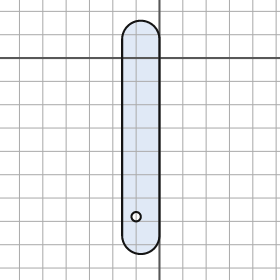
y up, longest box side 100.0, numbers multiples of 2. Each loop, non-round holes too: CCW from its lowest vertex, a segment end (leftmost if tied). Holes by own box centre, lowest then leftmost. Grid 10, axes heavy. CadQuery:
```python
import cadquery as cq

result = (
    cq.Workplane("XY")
    .moveTo(-16.0, -76.0)
    .threePointArc((-8.0, -84.0), (0.0, -76.0))
    .lineTo(0.0, 8.0)
    .threePointArc((-8.0, 16.0), (-16.0, 8.0))
    .close()
    .moveTo(-10.0, -68.0)
    .circle(2.0)
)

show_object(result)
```